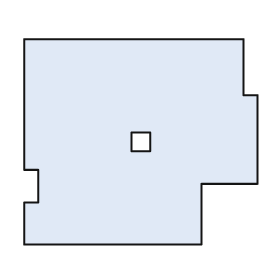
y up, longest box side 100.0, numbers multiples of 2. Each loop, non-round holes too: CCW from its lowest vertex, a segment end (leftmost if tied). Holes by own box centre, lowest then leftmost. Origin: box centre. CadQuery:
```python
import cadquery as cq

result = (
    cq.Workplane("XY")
    .moveTo(-50.0, -44.0)
    .lineTo(26.0, -44.0)
    .lineTo(26.0, -18.0)
    .lineTo(50.0, -18.0)
    .lineTo(50.0, 20.0)
    .lineTo(44.0, 20.0)
    .lineTo(44.0, 44.0)
    .lineTo(-50.0, 44.0)
    .lineTo(-50.0, -12.0)
    .lineTo(-44.0, -12.0)
    .lineTo(-44.0, -26.0)
    .lineTo(-50.0, -26.0)
    .close()
    .moveTo(-4.0, -4.0)
    .lineTo(4.0, -4.0)
    .lineTo(4.0, 4.0)
    .lineTo(-4.0, 4.0)
    .close()
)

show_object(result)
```